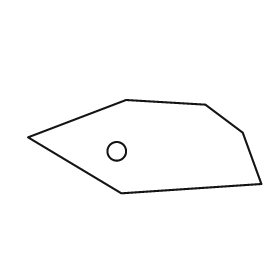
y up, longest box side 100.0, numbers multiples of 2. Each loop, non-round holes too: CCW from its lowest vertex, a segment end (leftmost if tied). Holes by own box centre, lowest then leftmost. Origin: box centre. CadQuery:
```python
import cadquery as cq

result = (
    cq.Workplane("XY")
    .moveTo(-10.0, -20.0)
    .lineTo(50.0, -16.0)
    .lineTo(42.0, 6.0)
    .lineTo(26.0, 18.0)
    .lineTo(-8.0, 20.0)
    .lineTo(-50.0, 4.0)
    .close()
    .moveTo(-12.0, -2.0)
    .circle(4.0)
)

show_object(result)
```